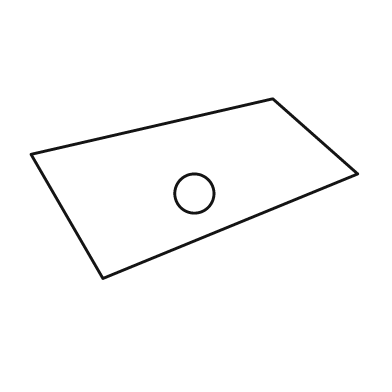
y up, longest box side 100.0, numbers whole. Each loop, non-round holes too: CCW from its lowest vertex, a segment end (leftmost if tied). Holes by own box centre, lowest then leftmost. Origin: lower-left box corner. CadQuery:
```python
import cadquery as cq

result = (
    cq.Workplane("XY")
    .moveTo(22.0, 0.0)
    .lineTo(100.0, 32.0)
    .lineTo(74.0, 55.0)
    .lineTo(0.0, 38.0)
    .close()
    .moveTo(50.0, 26.0)
    .circle(6.0)
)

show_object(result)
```